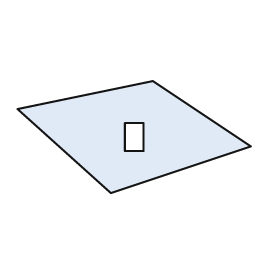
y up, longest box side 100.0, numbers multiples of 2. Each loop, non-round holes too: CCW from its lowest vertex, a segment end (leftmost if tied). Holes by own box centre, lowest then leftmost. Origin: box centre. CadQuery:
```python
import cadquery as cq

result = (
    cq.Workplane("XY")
    .moveTo(-10.0, -24.0)
    .lineTo(50.0, -4.0)
    .lineTo(8.0, 24.0)
    .lineTo(-50.0, 12.0)
    .close()
    .moveTo(-4.0, -6.0)
    .lineTo(4.0, -6.0)
    .lineTo(4.0, 6.0)
    .lineTo(-4.0, 6.0)
    .close()
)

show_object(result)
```